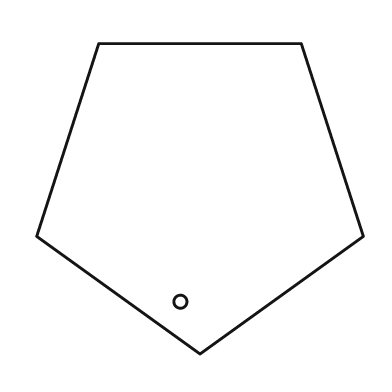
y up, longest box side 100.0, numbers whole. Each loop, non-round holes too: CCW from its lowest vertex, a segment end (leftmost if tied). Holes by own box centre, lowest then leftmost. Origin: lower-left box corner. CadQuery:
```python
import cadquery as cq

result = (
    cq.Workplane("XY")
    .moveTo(50.0, 0.0)
    .lineTo(100.0, 36.0)
    .lineTo(81.0, 95.0)
    .lineTo(19.0, 95.0)
    .lineTo(0.0, 36.0)
    .close()
    .moveTo(44.0, 16.0)
    .circle(2.0)
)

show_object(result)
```